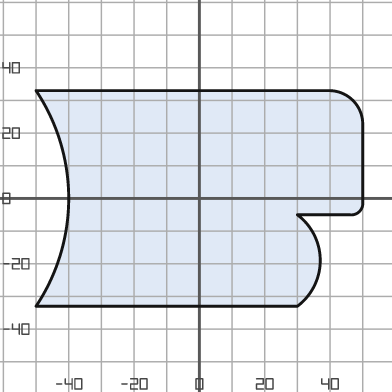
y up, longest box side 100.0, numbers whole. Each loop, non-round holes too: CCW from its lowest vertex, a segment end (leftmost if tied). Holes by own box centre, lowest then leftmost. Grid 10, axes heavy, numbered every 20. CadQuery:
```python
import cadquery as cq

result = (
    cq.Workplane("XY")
    .moveTo(-50.0, -33.0)
    .lineTo(30.0, -33.0)
    .threePointArc((37.0, -19.0), (30.0, -5.0))
    .lineTo(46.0, -5.0)
    .threePointArc((49.0, -4.0), (50.0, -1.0))
    .lineTo(50.0, 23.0)
    .threePointArc((47.0, 30.0), (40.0, 33.0))
    .lineTo(-50.0, 33.0)
    .threePointArc((-40.0, 0.0), (-50.0, -33.0))
    .close()
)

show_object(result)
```